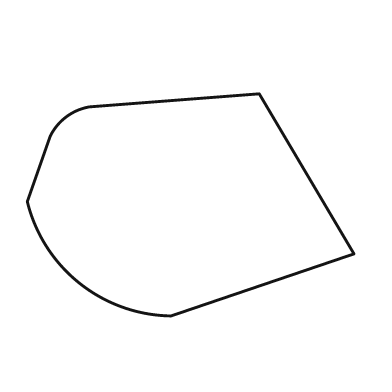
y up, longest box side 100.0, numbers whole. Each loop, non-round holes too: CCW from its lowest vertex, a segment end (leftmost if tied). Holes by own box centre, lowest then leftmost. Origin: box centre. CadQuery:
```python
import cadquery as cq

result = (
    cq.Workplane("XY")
    .moveTo(-6.0, -34.0)
    .lineTo(50.0, -15.0)
    .lineTo(21.0, 34.0)
    .lineTo(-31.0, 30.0)
    .threePointArc((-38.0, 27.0), (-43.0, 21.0))
    .lineTo(-50.0, 1.0)
    .threePointArc((-34.0, -24.0), (-6.0, -34.0))
    .close()
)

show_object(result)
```